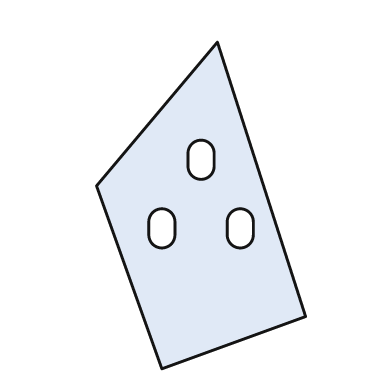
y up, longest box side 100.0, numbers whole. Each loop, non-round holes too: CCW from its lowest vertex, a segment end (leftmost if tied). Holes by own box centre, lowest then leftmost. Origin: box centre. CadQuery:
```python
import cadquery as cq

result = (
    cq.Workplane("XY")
    .moveTo(-12.0, -50.0)
    .lineTo(32.0, -34.0)
    .lineTo(5.0, 50.0)
    .lineTo(-32.0, 6.0)
    .close()
    .moveTo(-16.0, -9.0)
    .threePointArc((-12.0, -13.0), (-8.0, -9.0))
    .lineTo(-8.0, -5.0)
    .threePointArc((-12.0, -1.0), (-16.0, -5.0))
    .close()
    .moveTo(8.0, -9.0)
    .threePointArc((12.0, -13.0), (16.0, -9.0))
    .lineTo(16.0, -5.0)
    .threePointArc((12.0, -1.0), (8.0, -5.0))
    .close()
    .moveTo(-4.0, 12.0)
    .threePointArc((0.0, 8.0), (4.0, 12.0))
    .lineTo(4.0, 16.0)
    .threePointArc((0.0, 20.0), (-4.0, 16.0))
    .close()
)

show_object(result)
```